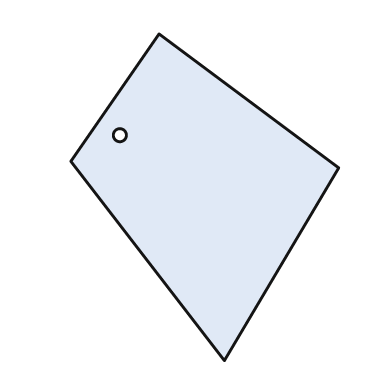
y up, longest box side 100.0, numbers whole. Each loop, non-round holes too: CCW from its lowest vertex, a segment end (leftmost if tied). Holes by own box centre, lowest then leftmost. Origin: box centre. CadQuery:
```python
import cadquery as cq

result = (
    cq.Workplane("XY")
    .moveTo(6.0, -50.0)
    .lineTo(41.0, 9.0)
    .lineTo(-14.0, 50.0)
    .lineTo(-41.0, 11.0)
    .close()
    .moveTo(-26.0, 19.0)
    .circle(2.0)
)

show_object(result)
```